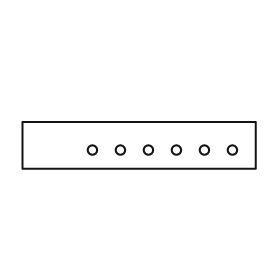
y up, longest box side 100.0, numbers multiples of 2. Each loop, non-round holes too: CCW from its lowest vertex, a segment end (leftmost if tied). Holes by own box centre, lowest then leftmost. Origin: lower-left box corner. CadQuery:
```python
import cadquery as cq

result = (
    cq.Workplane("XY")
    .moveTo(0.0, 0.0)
    .lineTo(100.0, 0.0)
    .lineTo(100.0, 20.0)
    .lineTo(0.0, 20.0)
    .close()
    .moveTo(30.0, 8.0)
    .circle(2.0)
    .moveTo(42.0, 8.0)
    .circle(2.0)
    .moveTo(54.0, 8.0)
    .circle(2.0)
    .moveTo(66.0, 8.0)
    .circle(2.0)
    .moveTo(78.0, 8.0)
    .circle(2.0)
    .moveTo(90.0, 8.0)
    .circle(2.0)
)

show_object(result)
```